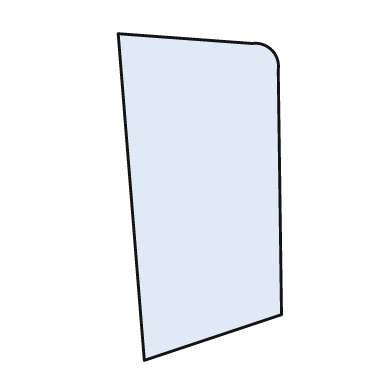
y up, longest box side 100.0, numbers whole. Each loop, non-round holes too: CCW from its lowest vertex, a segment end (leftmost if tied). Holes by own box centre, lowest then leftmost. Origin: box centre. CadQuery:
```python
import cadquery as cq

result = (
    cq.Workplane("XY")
    .moveTo(-17.0, -50.0)
    .lineTo(25.0, -36.0)
    .lineTo(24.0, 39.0)
    .threePointArc((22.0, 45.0), (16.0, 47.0))
    .lineTo(-25.0, 50.0)
    .close()
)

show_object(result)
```